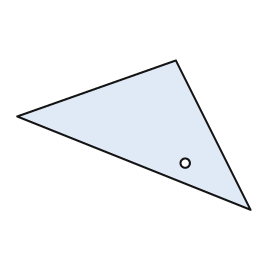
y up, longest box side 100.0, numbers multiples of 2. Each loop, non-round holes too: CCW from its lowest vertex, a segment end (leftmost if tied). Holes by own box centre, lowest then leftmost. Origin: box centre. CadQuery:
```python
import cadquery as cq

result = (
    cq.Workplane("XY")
    .moveTo(50.0, -32.0)
    .lineTo(18.0, 32.0)
    .lineTo(-50.0, 8.0)
    .close()
    .moveTo(22.0, -12.0)
    .circle(2.0)
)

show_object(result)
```